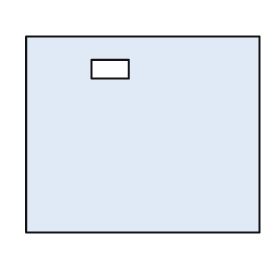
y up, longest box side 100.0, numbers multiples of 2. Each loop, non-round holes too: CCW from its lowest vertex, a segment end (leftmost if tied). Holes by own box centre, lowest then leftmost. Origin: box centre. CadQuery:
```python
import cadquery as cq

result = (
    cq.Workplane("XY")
    .moveTo(-50.0, -42.0)
    .lineTo(50.0, -42.0)
    .lineTo(50.0, 42.0)
    .lineTo(-50.0, 42.0)
    .close()
    .moveTo(-22.0, 24.0)
    .lineTo(-6.0, 24.0)
    .lineTo(-6.0, 32.0)
    .lineTo(-22.0, 32.0)
    .close()
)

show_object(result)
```